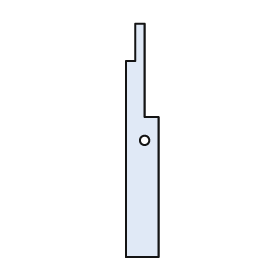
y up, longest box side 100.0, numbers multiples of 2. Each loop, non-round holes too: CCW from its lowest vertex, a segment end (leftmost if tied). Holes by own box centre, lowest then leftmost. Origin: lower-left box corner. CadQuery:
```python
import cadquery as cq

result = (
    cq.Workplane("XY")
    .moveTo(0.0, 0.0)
    .lineTo(14.0, 0.0)
    .lineTo(14.0, 60.0)
    .lineTo(8.0, 60.0)
    .lineTo(8.0, 100.0)
    .lineTo(4.0, 100.0)
    .lineTo(4.0, 84.0)
    .lineTo(0.0, 84.0)
    .close()
    .moveTo(8.0, 50.0)
    .circle(2.0)
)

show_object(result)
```